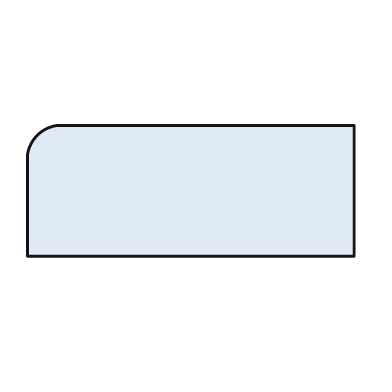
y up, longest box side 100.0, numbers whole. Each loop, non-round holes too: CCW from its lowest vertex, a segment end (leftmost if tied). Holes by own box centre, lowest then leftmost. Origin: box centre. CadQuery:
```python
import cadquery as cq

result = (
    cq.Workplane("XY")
    .moveTo(-50.0, -20.0)
    .lineTo(50.0, -20.0)
    .lineTo(50.0, 20.0)
    .lineTo(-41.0, 20.0)
    .threePointArc((-47.0, 17.0), (-50.0, 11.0))
    .close()
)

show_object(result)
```